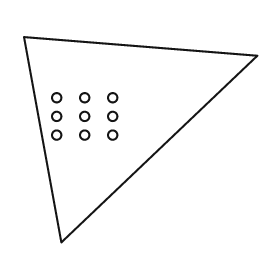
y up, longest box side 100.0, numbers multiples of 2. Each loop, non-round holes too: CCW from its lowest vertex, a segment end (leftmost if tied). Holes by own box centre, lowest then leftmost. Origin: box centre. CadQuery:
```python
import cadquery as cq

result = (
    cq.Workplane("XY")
    .moveTo(-34.0, -44.0)
    .lineTo(50.0, 36.0)
    .lineTo(-50.0, 44.0)
    .close()
    .moveTo(-36.0, 2.0)
    .circle(2.0)
    .moveTo(-24.0, 2.0)
    .circle(2.0)
    .moveTo(-12.0, 2.0)
    .circle(2.0)
    .moveTo(-36.0, 10.0)
    .circle(2.0)
    .moveTo(-24.0, 10.0)
    .circle(2.0)
    .moveTo(-12.0, 10.0)
    .circle(2.0)
    .moveTo(-36.0, 18.0)
    .circle(2.0)
    .moveTo(-24.0, 18.0)
    .circle(2.0)
    .moveTo(-12.0, 18.0)
    .circle(2.0)
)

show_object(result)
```